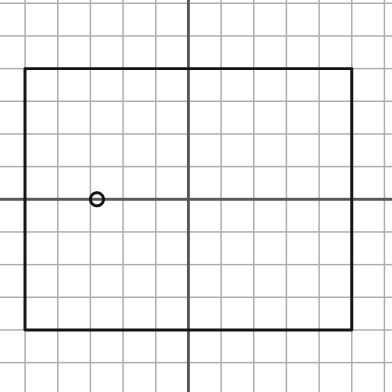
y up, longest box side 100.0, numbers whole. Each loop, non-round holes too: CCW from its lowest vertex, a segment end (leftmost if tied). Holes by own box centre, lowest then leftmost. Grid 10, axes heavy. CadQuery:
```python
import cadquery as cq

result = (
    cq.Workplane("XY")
    .moveTo(-50.0, -40.0)
    .lineTo(50.0, -40.0)
    .lineTo(50.0, 40.0)
    .lineTo(-50.0, 40.0)
    .close()
    .moveTo(-28.0, 0.0)
    .circle(2.0)
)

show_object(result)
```